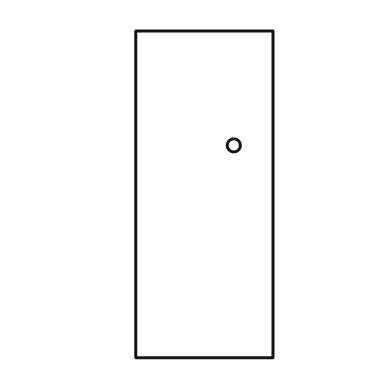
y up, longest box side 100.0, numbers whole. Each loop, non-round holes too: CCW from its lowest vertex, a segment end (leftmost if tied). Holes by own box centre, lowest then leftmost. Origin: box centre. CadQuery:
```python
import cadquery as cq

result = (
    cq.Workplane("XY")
    .moveTo(-21.0, -50.0)
    .lineTo(21.0, -50.0)
    .lineTo(21.0, 50.0)
    .lineTo(-21.0, 50.0)
    .close()
    .moveTo(9.0, 15.0)
    .circle(2.0)
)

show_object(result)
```